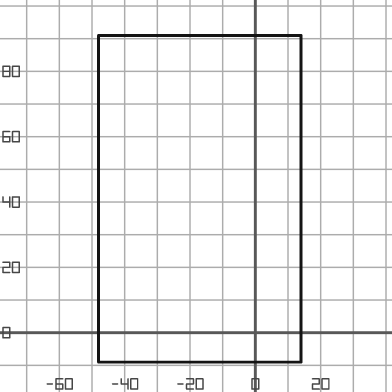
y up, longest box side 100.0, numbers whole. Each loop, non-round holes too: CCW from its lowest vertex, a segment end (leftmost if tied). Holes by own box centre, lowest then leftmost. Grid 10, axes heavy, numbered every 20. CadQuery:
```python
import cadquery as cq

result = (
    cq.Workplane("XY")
    .moveTo(-48.0, -9.0)
    .lineTo(14.0, -9.0)
    .lineTo(14.0, 91.0)
    .lineTo(-48.0, 91.0)
    .close()
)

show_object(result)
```